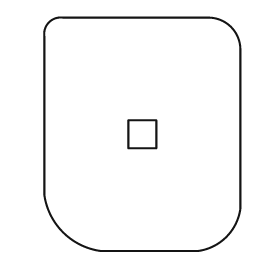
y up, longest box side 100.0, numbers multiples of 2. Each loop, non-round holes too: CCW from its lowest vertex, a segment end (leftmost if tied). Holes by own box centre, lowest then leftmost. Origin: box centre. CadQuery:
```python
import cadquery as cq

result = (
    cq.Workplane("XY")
    .moveTo(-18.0, -50.0)
    .lineTo(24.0, -50.0)
    .threePointArc((36.0, -44.0), (42.0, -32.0))
    .lineTo(42.0, 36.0)
    .threePointArc((38.0, 46.0), (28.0, 50.0))
    .lineTo(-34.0, 50.0)
    .threePointArc((-40.0, 48.0), (-42.0, 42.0))
    .lineTo(-42.0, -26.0)
    .threePointArc((-34.0, -42.0), (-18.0, -50.0))
    .close()
    .moveTo(-6.0, -6.0)
    .lineTo(6.0, -6.0)
    .lineTo(6.0, 6.0)
    .lineTo(-6.0, 6.0)
    .close()
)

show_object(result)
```